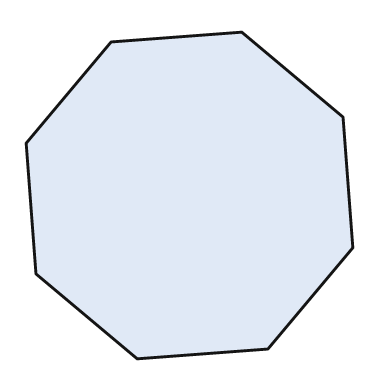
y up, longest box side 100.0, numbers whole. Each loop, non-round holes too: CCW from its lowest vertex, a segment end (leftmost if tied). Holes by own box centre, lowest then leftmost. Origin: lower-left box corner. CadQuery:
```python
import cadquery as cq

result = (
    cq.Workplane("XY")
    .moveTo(34.0, 0.0)
    .lineTo(74.0, 3.0)
    .lineTo(100.0, 34.0)
    .lineTo(97.0, 74.0)
    .lineTo(66.0, 100.0)
    .lineTo(26.0, 97.0)
    .lineTo(0.0, 66.0)
    .lineTo(3.0, 26.0)
    .close()
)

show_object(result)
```